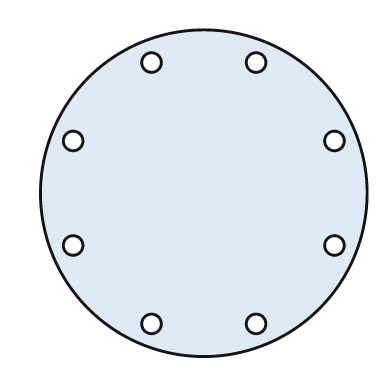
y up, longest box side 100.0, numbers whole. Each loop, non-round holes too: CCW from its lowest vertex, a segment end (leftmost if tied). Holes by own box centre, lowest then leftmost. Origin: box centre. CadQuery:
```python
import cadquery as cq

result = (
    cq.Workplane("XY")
    .moveTo(0.0, 0.0)
    .circle(50.0)
    .moveTo(-16.0, -40.0)
    .circle(3.0)
    .moveTo(16.0, -40.0)
    .circle(3.0)
    .moveTo(-40.0, -16.0)
    .circle(3.0)
    .moveTo(40.0, -16.0)
    .circle(3.0)
    .moveTo(-40.0, 16.0)
    .circle(3.0)
    .moveTo(40.0, 16.0)
    .circle(3.0)
    .moveTo(-16.0, 40.0)
    .circle(3.0)
    .moveTo(16.0, 40.0)
    .circle(3.0)
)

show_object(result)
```